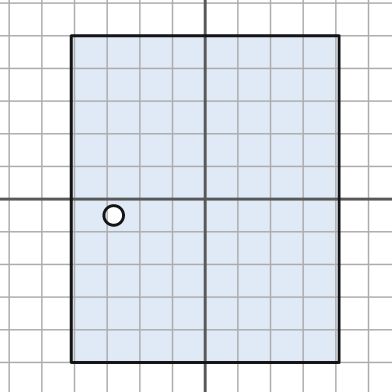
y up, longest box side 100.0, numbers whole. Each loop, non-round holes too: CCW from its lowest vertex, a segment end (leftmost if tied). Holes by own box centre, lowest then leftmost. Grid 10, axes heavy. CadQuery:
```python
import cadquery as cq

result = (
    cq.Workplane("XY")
    .moveTo(-41.0, -50.0)
    .lineTo(41.0, -50.0)
    .lineTo(41.0, 50.0)
    .lineTo(-41.0, 50.0)
    .close()
    .moveTo(-28.0, -5.0)
    .circle(3.0)
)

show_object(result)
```